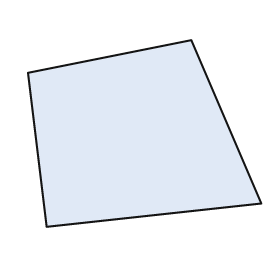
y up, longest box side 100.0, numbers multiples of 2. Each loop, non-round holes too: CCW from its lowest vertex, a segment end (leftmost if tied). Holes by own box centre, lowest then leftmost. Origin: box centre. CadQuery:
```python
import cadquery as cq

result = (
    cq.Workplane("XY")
    .moveTo(-42.0, -40.0)
    .lineTo(50.0, -30.0)
    .lineTo(20.0, 40.0)
    .lineTo(-50.0, 26.0)
    .close()
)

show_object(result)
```